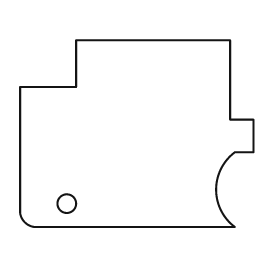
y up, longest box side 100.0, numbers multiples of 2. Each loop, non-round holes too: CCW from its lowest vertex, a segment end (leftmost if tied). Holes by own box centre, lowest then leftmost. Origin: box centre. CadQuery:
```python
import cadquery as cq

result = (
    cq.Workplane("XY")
    .moveTo(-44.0, -40.0)
    .lineTo(42.0, -40.0)
    .threePointArc((34.0, -24.0), (42.0, -8.0))
    .lineTo(50.0, -8.0)
    .lineTo(50.0, 6.0)
    .lineTo(40.0, 6.0)
    .lineTo(40.0, 40.0)
    .lineTo(-26.0, 40.0)
    .lineTo(-26.0, 20.0)
    .lineTo(-50.0, 20.0)
    .lineTo(-50.0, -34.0)
    .threePointArc((-48.0, -38.0), (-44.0, -40.0))
    .close()
    .moveTo(-30.0, -30.0)
    .circle(4.0)
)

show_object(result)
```